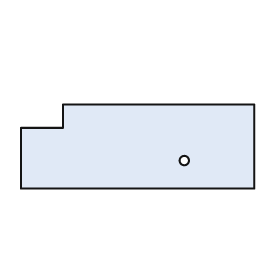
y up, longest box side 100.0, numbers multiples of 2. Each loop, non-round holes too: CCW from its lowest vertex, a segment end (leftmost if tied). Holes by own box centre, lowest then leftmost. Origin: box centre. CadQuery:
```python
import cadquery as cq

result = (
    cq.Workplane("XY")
    .moveTo(-50.0, -18.0)
    .lineTo(50.0, -18.0)
    .lineTo(50.0, 18.0)
    .lineTo(-32.0, 18.0)
    .lineTo(-32.0, 8.0)
    .lineTo(-50.0, 8.0)
    .close()
    .moveTo(20.0, -6.0)
    .circle(2.0)
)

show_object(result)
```